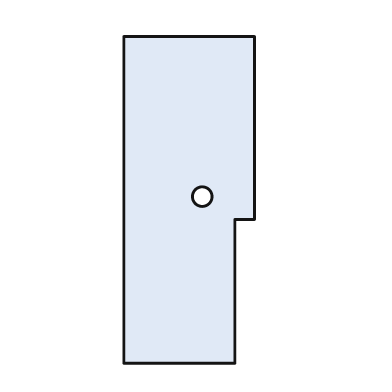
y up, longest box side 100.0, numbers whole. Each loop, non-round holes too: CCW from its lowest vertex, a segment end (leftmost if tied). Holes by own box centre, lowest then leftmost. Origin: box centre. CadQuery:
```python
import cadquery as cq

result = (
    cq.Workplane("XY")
    .moveTo(-20.0, -50.0)
    .lineTo(14.0, -50.0)
    .lineTo(14.0, -6.0)
    .lineTo(20.0, -6.0)
    .lineTo(20.0, 50.0)
    .lineTo(-20.0, 50.0)
    .close()
    .moveTo(4.0, 1.0)
    .circle(3.0)
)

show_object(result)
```